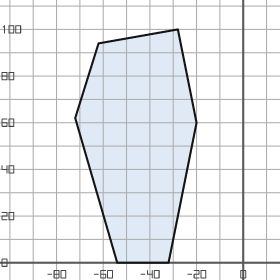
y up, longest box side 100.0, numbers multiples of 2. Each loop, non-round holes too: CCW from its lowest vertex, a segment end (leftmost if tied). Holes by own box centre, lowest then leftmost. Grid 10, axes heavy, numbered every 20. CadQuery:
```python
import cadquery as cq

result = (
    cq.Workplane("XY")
    .moveTo(-54.0, 0.0)
    .lineTo(-32.0, 0.0)
    .lineTo(-20.0, 60.0)
    .lineTo(-28.0, 100.0)
    .lineTo(-62.0, 94.0)
    .lineTo(-72.0, 62.0)
    .close()
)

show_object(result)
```